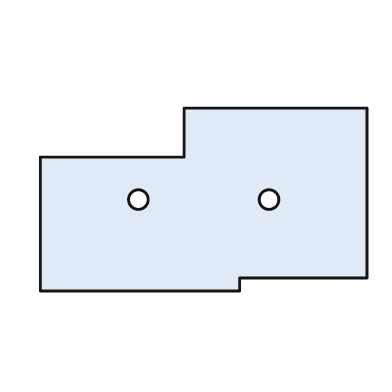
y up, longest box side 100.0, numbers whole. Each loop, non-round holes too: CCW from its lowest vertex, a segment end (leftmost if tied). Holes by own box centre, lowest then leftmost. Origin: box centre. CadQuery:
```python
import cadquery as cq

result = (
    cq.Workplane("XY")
    .moveTo(-50.0, -28.0)
    .lineTo(11.0, -28.0)
    .lineTo(11.0, -24.0)
    .lineTo(50.0, -24.0)
    .lineTo(50.0, 28.0)
    .lineTo(-6.0, 28.0)
    .lineTo(-6.0, 13.0)
    .lineTo(-50.0, 13.0)
    .close()
    .moveTo(-20.0, 0.0)
    .circle(3.0)
    .moveTo(20.0, 0.0)
    .circle(3.0)
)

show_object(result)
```